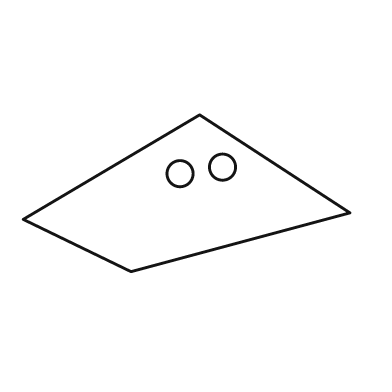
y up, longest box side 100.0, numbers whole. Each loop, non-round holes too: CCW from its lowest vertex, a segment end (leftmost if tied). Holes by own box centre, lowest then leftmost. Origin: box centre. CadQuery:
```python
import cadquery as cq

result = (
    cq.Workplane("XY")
    .moveTo(-17.0, -24.0)
    .lineTo(50.0, -6.0)
    .lineTo(4.0, 24.0)
    .lineTo(-50.0, -8.0)
    .close()
    .moveTo(-2.0, 6.0)
    .circle(4.0)
    .moveTo(11.0, 8.0)
    .circle(4.0)
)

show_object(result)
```